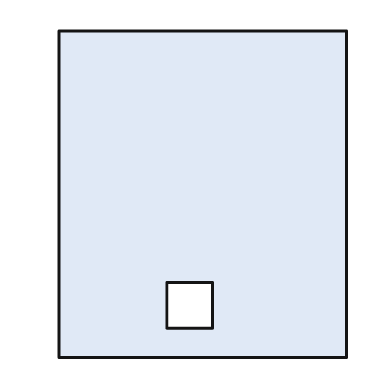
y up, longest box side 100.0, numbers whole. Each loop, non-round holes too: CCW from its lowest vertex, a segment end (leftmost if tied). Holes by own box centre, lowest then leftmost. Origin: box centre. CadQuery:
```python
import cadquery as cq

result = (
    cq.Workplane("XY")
    .moveTo(-44.0, -50.0)
    .lineTo(44.0, -50.0)
    .lineTo(44.0, 50.0)
    .lineTo(-44.0, 50.0)
    .close()
    .moveTo(-11.0, -41.0)
    .lineTo(3.0, -41.0)
    .lineTo(3.0, -27.0)
    .lineTo(-11.0, -27.0)
    .close()
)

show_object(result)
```